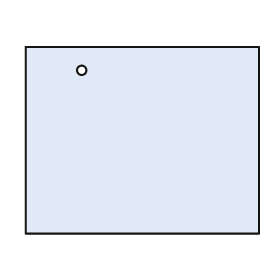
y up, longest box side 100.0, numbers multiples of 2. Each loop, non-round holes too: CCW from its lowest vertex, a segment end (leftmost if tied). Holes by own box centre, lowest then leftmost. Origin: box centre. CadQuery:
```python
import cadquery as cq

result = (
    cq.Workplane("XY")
    .moveTo(-50.0, -40.0)
    .lineTo(50.0, -40.0)
    .lineTo(50.0, 40.0)
    .lineTo(-50.0, 40.0)
    .close()
    .moveTo(-26.0, 30.0)
    .circle(2.0)
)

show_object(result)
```